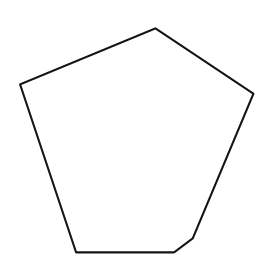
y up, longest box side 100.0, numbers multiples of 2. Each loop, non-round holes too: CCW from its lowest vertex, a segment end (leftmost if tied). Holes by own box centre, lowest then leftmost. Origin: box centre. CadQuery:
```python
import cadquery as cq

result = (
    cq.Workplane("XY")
    .moveTo(-26.0, -48.0)
    .lineTo(16.0, -48.0)
    .lineTo(24.0, -42.0)
    .lineTo(50.0, 20.0)
    .lineTo(8.0, 48.0)
    .lineTo(-50.0, 24.0)
    .close()
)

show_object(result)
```